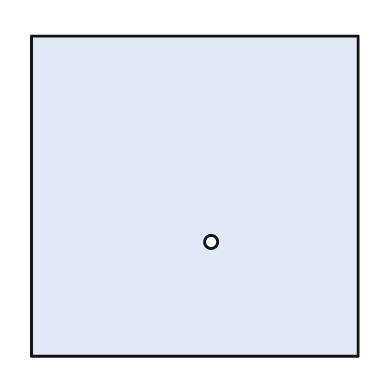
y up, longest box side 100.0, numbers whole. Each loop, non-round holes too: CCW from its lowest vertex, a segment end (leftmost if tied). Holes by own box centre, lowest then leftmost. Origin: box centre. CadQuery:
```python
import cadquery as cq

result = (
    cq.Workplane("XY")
    .moveTo(-50.0, -49.0)
    .lineTo(50.0, -49.0)
    .lineTo(50.0, 49.0)
    .lineTo(-50.0, 49.0)
    .close()
    .moveTo(5.0, -14.0)
    .circle(2.0)
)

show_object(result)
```